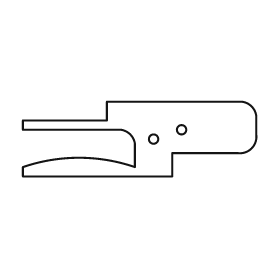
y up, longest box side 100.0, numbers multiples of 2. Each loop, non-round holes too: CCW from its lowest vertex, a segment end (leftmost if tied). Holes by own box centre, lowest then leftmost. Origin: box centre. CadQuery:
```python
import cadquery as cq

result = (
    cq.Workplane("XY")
    .moveTo(-50.0, -16.0)
    .lineTo(14.0, -16.0)
    .lineTo(14.0, -6.0)
    .lineTo(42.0, -6.0)
    .threePointArc((48.0, -4.0), (50.0, 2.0))
    .lineTo(50.0, 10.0)
    .threePointArc((48.0, 14.0), (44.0, 16.0))
    .lineTo(-14.0, 16.0)
    .lineTo(-14.0, 8.0)
    .lineTo(-50.0, 8.0)
    .lineTo(-50.0, 4.0)
    .lineTo(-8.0, 4.0)
    .threePointArc((-4.0, 2.0), (-2.0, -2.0))
    .lineTo(-2.0, -12.0)
    .threePointArc((-26.0, -8.0), (-50.0, -12.0))
    .close()
    .moveTo(6.0, 0.0)
    .circle(2.0)
    .moveTo(18.0, 4.0)
    .circle(2.0)
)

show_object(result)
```